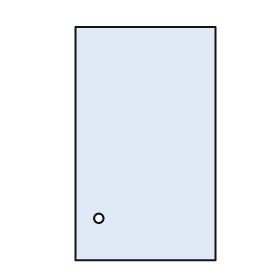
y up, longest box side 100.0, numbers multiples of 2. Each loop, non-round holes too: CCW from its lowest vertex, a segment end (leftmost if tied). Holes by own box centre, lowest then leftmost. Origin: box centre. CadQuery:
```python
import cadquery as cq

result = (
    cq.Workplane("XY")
    .moveTo(-30.0, -50.0)
    .lineTo(30.0, -50.0)
    .lineTo(30.0, 50.0)
    .lineTo(-30.0, 50.0)
    .close()
    .moveTo(-20.0, -32.0)
    .circle(2.0)
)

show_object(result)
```